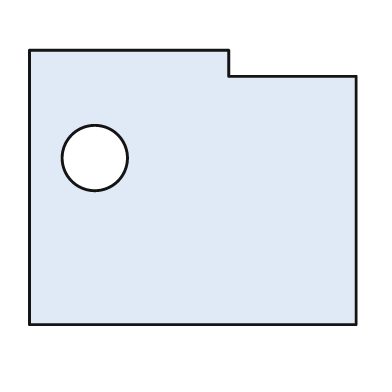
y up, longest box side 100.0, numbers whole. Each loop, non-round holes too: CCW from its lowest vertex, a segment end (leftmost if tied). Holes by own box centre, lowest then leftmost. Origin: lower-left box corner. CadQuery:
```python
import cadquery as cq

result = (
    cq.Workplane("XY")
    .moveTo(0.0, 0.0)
    .lineTo(100.0, 0.0)
    .lineTo(100.0, 76.0)
    .lineTo(61.0, 76.0)
    .lineTo(61.0, 84.0)
    .lineTo(0.0, 84.0)
    .close()
    .moveTo(20.0, 51.0)
    .circle(10.0)
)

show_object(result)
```